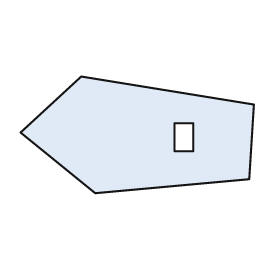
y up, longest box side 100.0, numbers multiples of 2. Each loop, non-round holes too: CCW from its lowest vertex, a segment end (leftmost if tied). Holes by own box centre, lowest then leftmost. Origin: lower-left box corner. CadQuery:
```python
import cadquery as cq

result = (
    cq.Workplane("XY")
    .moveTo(32.0, 0.0)
    .lineTo(98.0, 6.0)
    .lineTo(100.0, 38.0)
    .lineTo(26.0, 50.0)
    .lineTo(0.0, 26.0)
    .close()
    .moveTo(66.0, 18.0)
    .lineTo(74.0, 18.0)
    .lineTo(74.0, 30.0)
    .lineTo(66.0, 30.0)
    .close()
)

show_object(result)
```